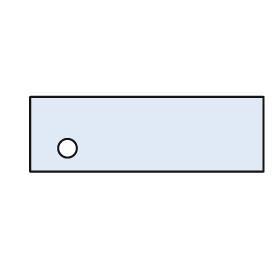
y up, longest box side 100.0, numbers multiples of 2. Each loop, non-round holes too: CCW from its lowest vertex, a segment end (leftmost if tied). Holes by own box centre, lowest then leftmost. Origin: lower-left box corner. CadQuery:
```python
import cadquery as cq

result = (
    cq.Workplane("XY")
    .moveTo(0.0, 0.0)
    .lineTo(100.0, 0.0)
    .lineTo(100.0, 32.0)
    .lineTo(0.0, 32.0)
    .close()
    .moveTo(16.0, 10.0)
    .circle(4.0)
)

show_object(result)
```